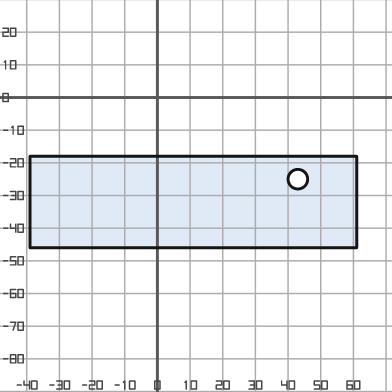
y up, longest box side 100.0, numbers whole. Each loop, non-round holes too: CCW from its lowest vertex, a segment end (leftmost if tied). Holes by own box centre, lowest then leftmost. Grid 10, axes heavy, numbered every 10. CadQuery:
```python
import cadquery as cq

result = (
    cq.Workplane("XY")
    .moveTo(-39.0, -46.0)
    .lineTo(61.0, -46.0)
    .lineTo(61.0, -18.0)
    .lineTo(-39.0, -18.0)
    .close()
    .moveTo(43.0, -25.0)
    .circle(3.0)
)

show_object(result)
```